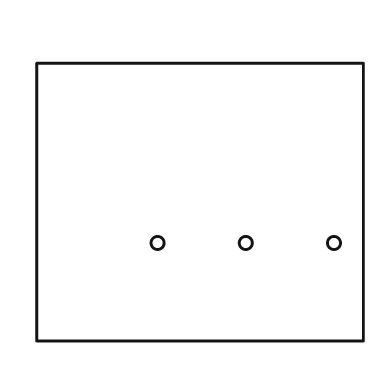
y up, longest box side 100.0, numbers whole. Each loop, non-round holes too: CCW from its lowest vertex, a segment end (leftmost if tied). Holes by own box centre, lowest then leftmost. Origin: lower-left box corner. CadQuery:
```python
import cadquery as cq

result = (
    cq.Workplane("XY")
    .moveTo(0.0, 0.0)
    .lineTo(100.0, 0.0)
    .lineTo(100.0, 85.0)
    .lineTo(0.0, 85.0)
    .close()
    .moveTo(37.0, 30.0)
    .circle(2.0)
    .moveTo(64.0, 30.0)
    .circle(2.0)
    .moveTo(91.0, 30.0)
    .circle(2.0)
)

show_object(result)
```